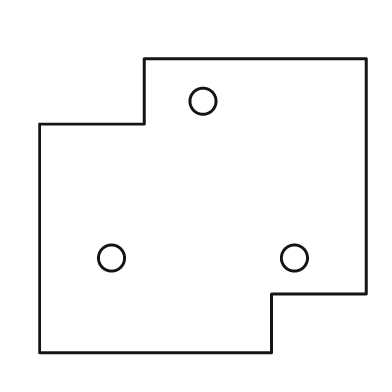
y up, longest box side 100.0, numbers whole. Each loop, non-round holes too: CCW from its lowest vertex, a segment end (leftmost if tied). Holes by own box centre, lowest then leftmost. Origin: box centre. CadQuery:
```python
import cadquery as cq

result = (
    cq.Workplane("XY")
    .moveTo(-50.0, -45.0)
    .lineTo(21.0, -45.0)
    .lineTo(21.0, -27.0)
    .lineTo(50.0, -27.0)
    .lineTo(50.0, 45.0)
    .lineTo(-18.0, 45.0)
    .lineTo(-18.0, 25.0)
    .lineTo(-50.0, 25.0)
    .close()
    .moveTo(-28.0, -16.0)
    .circle(4.0)
    .moveTo(28.0, -16.0)
    .circle(4.0)
    .moveTo(0.0, 32.0)
    .circle(4.0)
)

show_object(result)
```